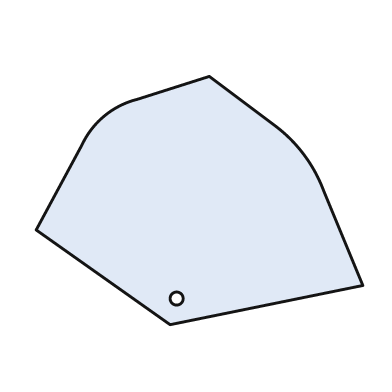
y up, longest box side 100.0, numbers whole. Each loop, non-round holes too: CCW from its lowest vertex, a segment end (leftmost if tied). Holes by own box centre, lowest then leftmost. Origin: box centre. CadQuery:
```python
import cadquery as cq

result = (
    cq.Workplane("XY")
    .moveTo(-9.0, -38.0)
    .lineTo(50.0, -26.0)
    .lineTo(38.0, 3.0)
    .threePointArc((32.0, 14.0), (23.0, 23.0))
    .lineTo(3.0, 38.0)
    .lineTo(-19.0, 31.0)
    .threePointArc((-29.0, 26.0), (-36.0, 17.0))
    .lineTo(-50.0, -9.0)
    .close()
    .moveTo(-7.0, -30.0)
    .circle(2.0)
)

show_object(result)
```